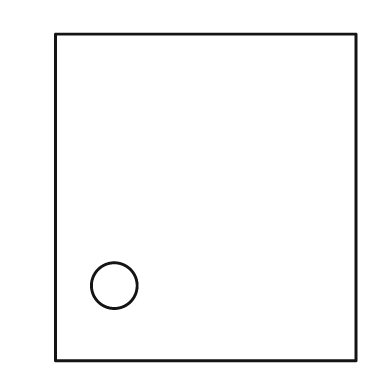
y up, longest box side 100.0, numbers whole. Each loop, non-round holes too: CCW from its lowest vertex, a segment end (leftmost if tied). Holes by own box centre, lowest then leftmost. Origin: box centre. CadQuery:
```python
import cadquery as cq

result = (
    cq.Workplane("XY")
    .moveTo(-46.0, -50.0)
    .lineTo(46.0, -50.0)
    .lineTo(46.0, 50.0)
    .lineTo(-46.0, 50.0)
    .close()
    .moveTo(-28.0, -27.0)
    .circle(7.0)
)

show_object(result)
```